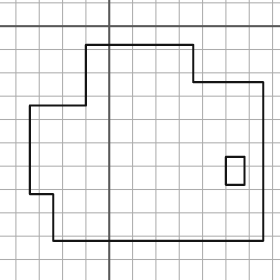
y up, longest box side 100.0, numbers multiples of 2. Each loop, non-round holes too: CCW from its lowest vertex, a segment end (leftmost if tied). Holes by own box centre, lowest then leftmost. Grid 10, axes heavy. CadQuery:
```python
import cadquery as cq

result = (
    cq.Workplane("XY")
    .moveTo(-24.0, -92.0)
    .lineTo(66.0, -92.0)
    .lineTo(66.0, -24.0)
    .lineTo(36.0, -24.0)
    .lineTo(36.0, -8.0)
    .lineTo(-10.0, -8.0)
    .lineTo(-10.0, -34.0)
    .lineTo(-34.0, -34.0)
    .lineTo(-34.0, -72.0)
    .lineTo(-24.0, -72.0)
    .close()
    .moveTo(50.0, -68.0)
    .lineTo(58.0, -68.0)
    .lineTo(58.0, -56.0)
    .lineTo(50.0, -56.0)
    .close()
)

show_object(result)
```